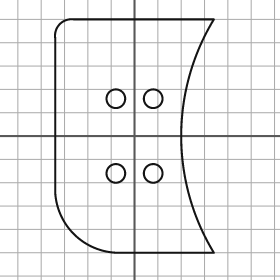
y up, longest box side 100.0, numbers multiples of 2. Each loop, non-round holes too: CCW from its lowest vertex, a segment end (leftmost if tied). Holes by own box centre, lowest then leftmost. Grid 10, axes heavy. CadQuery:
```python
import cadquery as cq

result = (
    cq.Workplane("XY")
    .moveTo(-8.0, -50.0)
    .lineTo(34.0, -50.0)
    .threePointArc((20.0, 0.0), (34.0, 50.0))
    .lineTo(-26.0, 50.0)
    .threePointArc((-32.0, 48.0), (-34.0, 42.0))
    .lineTo(-34.0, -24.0)
    .threePointArc((-26.0, -42.0), (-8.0, -50.0))
    .close()
    .moveTo(-8.0, -16.0)
    .circle(4.0)
    .moveTo(8.0, -16.0)
    .circle(4.0)
    .moveTo(-8.0, 16.0)
    .circle(4.0)
    .moveTo(8.0, 16.0)
    .circle(4.0)
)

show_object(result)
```